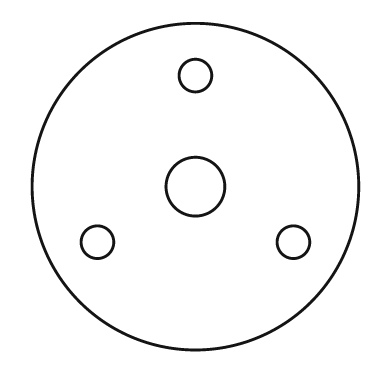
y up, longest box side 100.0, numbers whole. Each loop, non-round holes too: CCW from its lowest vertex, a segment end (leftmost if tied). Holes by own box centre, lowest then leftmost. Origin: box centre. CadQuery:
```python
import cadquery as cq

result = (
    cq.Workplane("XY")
    .moveTo(0.0, 0.0)
    .circle(50.0)
    .moveTo(-30.0, -17.0)
    .circle(5.0)
    .moveTo(30.0, -17.0)
    .circle(5.0)
    .moveTo(0.0, 0.0)
    .circle(9.0)
    .moveTo(0.0, 34.0)
    .circle(5.0)
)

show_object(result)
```